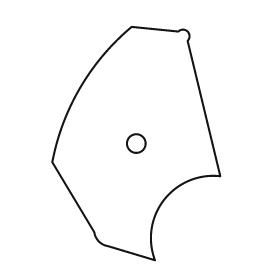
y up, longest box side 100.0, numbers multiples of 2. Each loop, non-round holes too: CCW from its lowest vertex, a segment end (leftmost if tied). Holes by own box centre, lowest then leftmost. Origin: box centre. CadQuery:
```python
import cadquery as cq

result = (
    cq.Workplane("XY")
    .moveTo(8.0, -50.0)
    .threePointArc((12.0, -24.0), (36.0, -14.0))
    .lineTo(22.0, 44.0)
    .threePointArc((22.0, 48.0), (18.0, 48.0))
    .lineTo(-2.0, 50.0)
    .threePointArc((-24.0, 24.0), (-36.0, -8.0))
    .lineTo(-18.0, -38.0)
    .threePointArc((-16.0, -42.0), (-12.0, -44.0))
    .close()
    .moveTo(0.0, 0.0)
    .circle(4.0)
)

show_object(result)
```